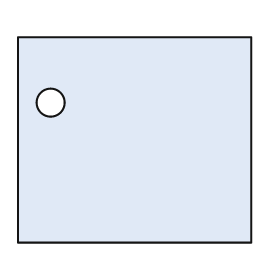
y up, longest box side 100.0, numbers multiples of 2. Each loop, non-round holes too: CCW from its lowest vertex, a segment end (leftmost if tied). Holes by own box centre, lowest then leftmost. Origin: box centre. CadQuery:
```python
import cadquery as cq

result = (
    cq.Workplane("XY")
    .moveTo(-50.0, -44.0)
    .lineTo(50.0, -44.0)
    .lineTo(50.0, 44.0)
    .lineTo(-50.0, 44.0)
    .close()
    .moveTo(-36.0, 16.0)
    .circle(6.0)
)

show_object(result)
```